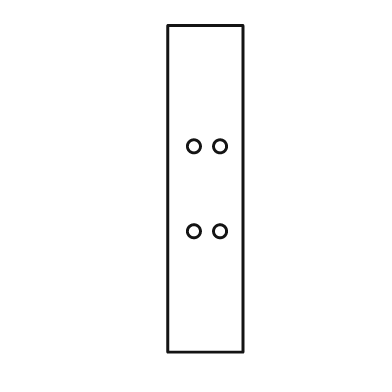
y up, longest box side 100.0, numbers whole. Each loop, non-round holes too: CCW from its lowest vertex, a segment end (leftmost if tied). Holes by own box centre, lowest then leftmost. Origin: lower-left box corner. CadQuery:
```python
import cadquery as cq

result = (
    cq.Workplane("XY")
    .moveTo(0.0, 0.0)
    .lineTo(23.0, 0.0)
    .lineTo(23.0, 100.0)
    .lineTo(0.0, 100.0)
    .close()
    .moveTo(8.0, 37.0)
    .circle(2.0)
    .moveTo(16.0, 37.0)
    .circle(2.0)
    .moveTo(8.0, 63.0)
    .circle(2.0)
    .moveTo(16.0, 63.0)
    .circle(2.0)
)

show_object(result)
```